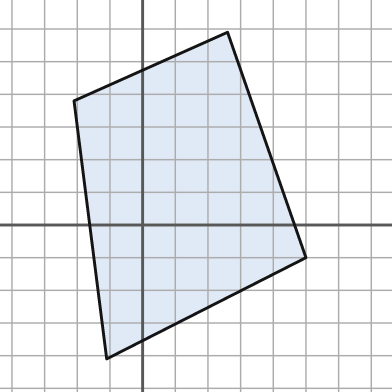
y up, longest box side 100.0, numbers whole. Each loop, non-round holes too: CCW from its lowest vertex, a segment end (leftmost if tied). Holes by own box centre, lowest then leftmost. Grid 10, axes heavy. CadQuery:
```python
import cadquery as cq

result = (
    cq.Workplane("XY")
    .moveTo(-11.0, -41.0)
    .lineTo(50.0, -10.0)
    .lineTo(26.0, 59.0)
    .lineTo(-21.0, 38.0)
    .close()
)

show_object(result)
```